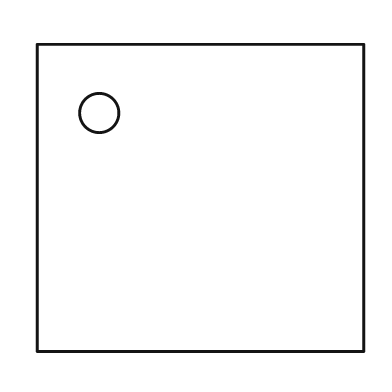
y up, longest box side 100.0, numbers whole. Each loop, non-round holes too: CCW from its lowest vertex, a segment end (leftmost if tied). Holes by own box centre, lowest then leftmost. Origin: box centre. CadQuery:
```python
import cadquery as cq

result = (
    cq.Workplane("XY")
    .moveTo(-50.0, -47.0)
    .lineTo(50.0, -47.0)
    .lineTo(50.0, 47.0)
    .lineTo(-50.0, 47.0)
    .close()
    .moveTo(-31.0, 26.0)
    .circle(6.0)
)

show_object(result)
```